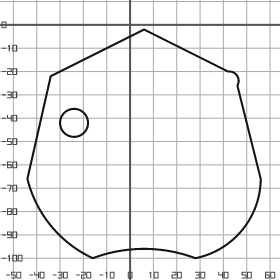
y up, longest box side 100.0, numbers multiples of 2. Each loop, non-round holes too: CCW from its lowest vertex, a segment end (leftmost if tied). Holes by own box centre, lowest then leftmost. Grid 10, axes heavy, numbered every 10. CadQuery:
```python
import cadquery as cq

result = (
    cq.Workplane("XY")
    .moveTo(-16.0, -100.0)
    .threePointArc((6.0, -96.0), (28.0, -100.0))
    .threePointArc((48.0, -88.0), (56.0, -66.0))
    .lineTo(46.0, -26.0)
    .threePointArc((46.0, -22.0), (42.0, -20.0))
    .lineTo(6.0, -2.0)
    .lineTo(-34.0, -22.0)
    .lineTo(-44.0, -66.0)
    .threePointArc((-34.0, -86.0), (-16.0, -100.0))
    .close()
    .moveTo(-24.0, -42.0)
    .circle(6.0)
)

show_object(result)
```